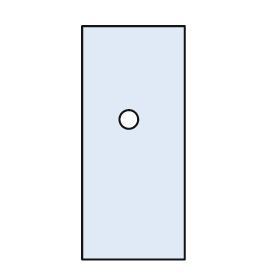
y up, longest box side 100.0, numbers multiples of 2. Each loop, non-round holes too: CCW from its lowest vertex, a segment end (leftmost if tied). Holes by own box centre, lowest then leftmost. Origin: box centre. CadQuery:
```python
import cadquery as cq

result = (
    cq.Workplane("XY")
    .moveTo(-22.0, -50.0)
    .lineTo(22.0, -50.0)
    .lineTo(22.0, 50.0)
    .lineTo(-22.0, 50.0)
    .close()
    .moveTo(-2.0, 10.0)
    .circle(4.0)
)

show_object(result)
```